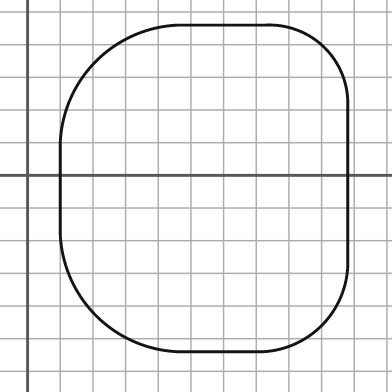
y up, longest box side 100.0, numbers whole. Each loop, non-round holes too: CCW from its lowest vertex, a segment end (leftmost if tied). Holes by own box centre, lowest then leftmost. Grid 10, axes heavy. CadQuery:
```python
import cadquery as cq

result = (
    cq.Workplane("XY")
    .moveTo(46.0, -54.0)
    .lineTo(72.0, -54.0)
    .threePointArc((90.0, -46.0), (98.0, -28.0))
    .lineTo(98.0, 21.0)
    .threePointArc((91.0, 39.0), (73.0, 46.0))
    .lineTo(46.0, 46.0)
    .threePointArc((21.0, 35.0), (10.0, 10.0))
    .lineTo(10.0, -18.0)
    .threePointArc((21.0, -43.0), (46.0, -54.0))
    .close()
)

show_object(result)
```